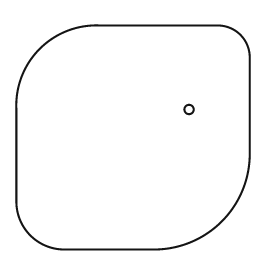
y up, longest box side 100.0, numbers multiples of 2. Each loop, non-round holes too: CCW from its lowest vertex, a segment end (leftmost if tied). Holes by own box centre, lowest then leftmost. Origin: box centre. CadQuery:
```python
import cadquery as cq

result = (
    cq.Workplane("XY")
    .moveTo(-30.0, -48.0)
    .lineTo(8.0, -48.0)
    .threePointArc((38.0, -36.0), (50.0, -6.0))
    .lineTo(50.0, 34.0)
    .threePointArc((46.0, 44.0), (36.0, 48.0))
    .lineTo(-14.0, 48.0)
    .threePointArc((-40.0, 38.0), (-50.0, 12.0))
    .lineTo(-50.0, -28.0)
    .threePointArc((-44.0, -42.0), (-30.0, -48.0))
    .close()
    .moveTo(24.0, 12.0)
    .circle(2.0)
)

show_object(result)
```